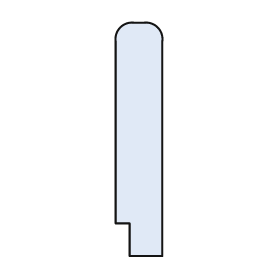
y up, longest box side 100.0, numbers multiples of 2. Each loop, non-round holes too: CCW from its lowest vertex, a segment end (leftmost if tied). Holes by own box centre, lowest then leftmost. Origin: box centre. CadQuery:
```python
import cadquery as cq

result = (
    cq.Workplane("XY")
    .moveTo(-4.0, -50.0)
    .lineTo(10.0, -50.0)
    .lineTo(10.0, 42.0)
    .threePointArc((8.0, 48.0), (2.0, 50.0))
    .lineTo(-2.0, 50.0)
    .threePointArc((-8.0, 48.0), (-10.0, 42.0))
    .lineTo(-10.0, -36.0)
    .lineTo(-4.0, -36.0)
    .close()
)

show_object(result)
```